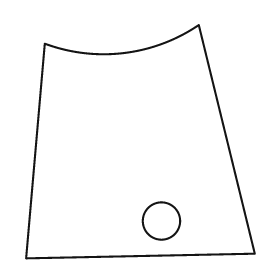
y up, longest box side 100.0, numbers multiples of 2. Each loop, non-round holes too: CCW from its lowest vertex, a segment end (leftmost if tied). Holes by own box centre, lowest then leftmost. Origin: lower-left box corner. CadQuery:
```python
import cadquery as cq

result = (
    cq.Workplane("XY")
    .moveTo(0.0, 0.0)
    .lineTo(98.0, 2.0)
    .lineTo(74.0, 100.0)
    .threePointArc((42.0, 88.0), (8.0, 92.0))
    .close()
    .moveTo(58.0, 16.0)
    .circle(8.0)
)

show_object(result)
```